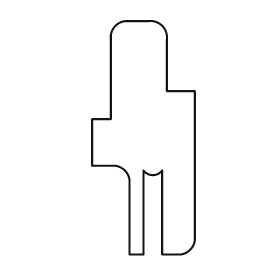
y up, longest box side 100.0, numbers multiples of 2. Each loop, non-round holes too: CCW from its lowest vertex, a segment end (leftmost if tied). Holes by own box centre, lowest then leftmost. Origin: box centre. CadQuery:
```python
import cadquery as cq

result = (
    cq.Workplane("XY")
    .moveTo(-6.0, -50.0)
    .lineTo(0.0, -50.0)
    .lineTo(0.0, -14.0)
    .threePointArc((4.0, -16.0), (8.0, -14.0))
    .lineTo(8.0, -50.0)
    .lineTo(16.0, -50.0)
    .threePointArc((20.0, -48.0), (22.0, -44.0))
    .lineTo(22.0, 20.0)
    .lineTo(10.0, 20.0)
    .lineTo(10.0, 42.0)
    .threePointArc((8.0, 48.0), (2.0, 50.0))
    .lineTo(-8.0, 50.0)
    .threePointArc((-12.0, 48.0), (-14.0, 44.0))
    .lineTo(-14.0, 8.0)
    .lineTo(-22.0, 8.0)
    .lineTo(-22.0, -12.0)
    .lineTo(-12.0, -12.0)
    .threePointArc((-8.0, -14.0), (-6.0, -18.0))
    .close()
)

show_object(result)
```